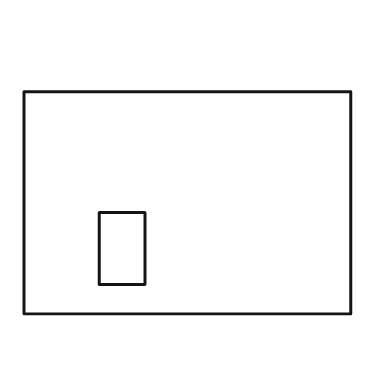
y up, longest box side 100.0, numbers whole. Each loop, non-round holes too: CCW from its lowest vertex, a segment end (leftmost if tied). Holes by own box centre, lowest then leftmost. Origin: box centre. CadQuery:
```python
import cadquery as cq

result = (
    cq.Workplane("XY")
    .moveTo(-50.0, -34.0)
    .lineTo(50.0, -34.0)
    .lineTo(50.0, 34.0)
    .lineTo(-50.0, 34.0)
    .close()
    .moveTo(-27.0, -25.0)
    .lineTo(-13.0, -25.0)
    .lineTo(-13.0, -3.0)
    .lineTo(-27.0, -3.0)
    .close()
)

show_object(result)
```